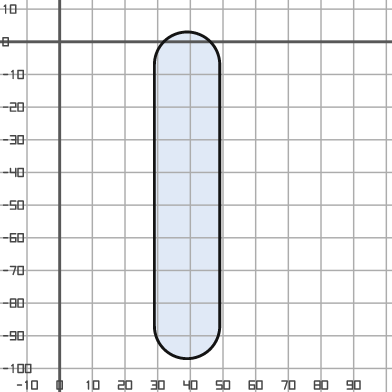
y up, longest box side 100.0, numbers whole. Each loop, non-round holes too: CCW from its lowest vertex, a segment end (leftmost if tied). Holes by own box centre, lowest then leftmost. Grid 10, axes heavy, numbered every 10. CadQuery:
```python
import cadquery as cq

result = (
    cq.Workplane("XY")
    .moveTo(29.0, -87.0)
    .threePointArc((39.0, -97.0), (49.0, -87.0))
    .lineTo(49.0, -7.0)
    .threePointArc((39.0, 3.0), (29.0, -7.0))
    .close()
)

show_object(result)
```